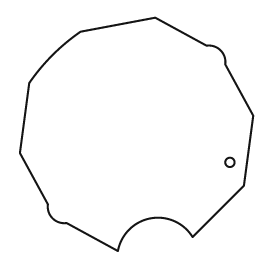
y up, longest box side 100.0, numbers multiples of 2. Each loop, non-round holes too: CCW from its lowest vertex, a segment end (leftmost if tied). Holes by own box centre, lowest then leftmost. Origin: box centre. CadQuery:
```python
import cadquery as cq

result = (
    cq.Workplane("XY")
    .moveTo(-8.0, -50.0)
    .threePointArc((6.0, -36.0), (24.0, -44.0))
    .lineTo(46.0, -22.0)
    .lineTo(50.0, 8.0)
    .lineTo(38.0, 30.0)
    .threePointArc((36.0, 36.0), (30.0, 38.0))
    .lineTo(8.0, 50.0)
    .lineTo(-24.0, 44.0)
    .threePointArc((-36.0, 34.0), (-46.0, 22.0))
    .lineTo(-50.0, -8.0)
    .lineTo(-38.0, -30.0)
    .threePointArc((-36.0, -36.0), (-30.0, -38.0))
    .close()
    .moveTo(40.0, -12.0)
    .circle(2.0)
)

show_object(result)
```